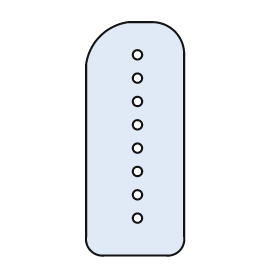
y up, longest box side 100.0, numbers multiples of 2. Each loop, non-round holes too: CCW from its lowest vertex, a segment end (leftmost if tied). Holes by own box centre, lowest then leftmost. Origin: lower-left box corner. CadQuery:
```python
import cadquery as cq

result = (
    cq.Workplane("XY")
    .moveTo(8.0, 0.0)
    .lineTo(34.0, 0.0)
    .threePointArc((40.0, 2.0), (42.0, 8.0))
    .lineTo(42.0, 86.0)
    .threePointArc((38.0, 96.0), (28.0, 100.0))
    .lineTo(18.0, 100.0)
    .threePointArc((6.0, 94.0), (0.0, 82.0))
    .lineTo(0.0, 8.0)
    .threePointArc((2.0, 2.0), (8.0, 0.0))
    .close()
    .moveTo(22.0, 16.0)
    .circle(2.0)
    .moveTo(22.0, 26.0)
    .circle(2.0)
    .moveTo(22.0, 36.0)
    .circle(2.0)
    .moveTo(22.0, 46.0)
    .circle(2.0)
    .moveTo(22.0, 56.0)
    .circle(2.0)
    .moveTo(22.0, 66.0)
    .circle(2.0)
    .moveTo(22.0, 76.0)
    .circle(2.0)
    .moveTo(22.0, 86.0)
    .circle(2.0)
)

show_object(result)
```